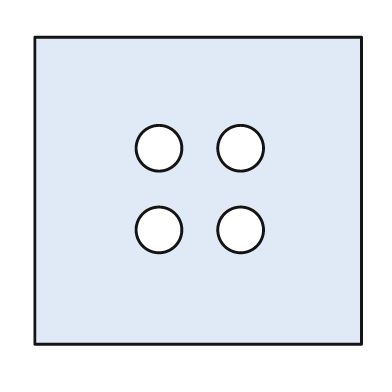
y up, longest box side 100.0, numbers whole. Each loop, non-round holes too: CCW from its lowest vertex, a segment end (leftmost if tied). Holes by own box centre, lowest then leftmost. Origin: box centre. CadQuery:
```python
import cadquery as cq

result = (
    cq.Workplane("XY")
    .moveTo(-50.0, -47.0)
    .lineTo(50.0, -47.0)
    .lineTo(50.0, 47.0)
    .lineTo(-50.0, 47.0)
    .close()
    .moveTo(-12.0, -12.0)
    .circle(7.0)
    .moveTo(13.0, -12.0)
    .circle(7.0)
    .moveTo(-12.0, 13.0)
    .circle(7.0)
    .moveTo(13.0, 13.0)
    .circle(7.0)
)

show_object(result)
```